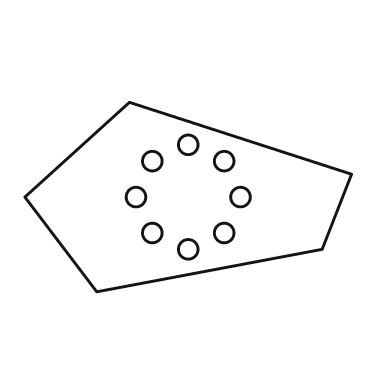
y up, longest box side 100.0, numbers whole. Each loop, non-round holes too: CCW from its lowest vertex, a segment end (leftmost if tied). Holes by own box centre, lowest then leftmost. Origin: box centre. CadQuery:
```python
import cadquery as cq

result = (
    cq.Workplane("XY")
    .moveTo(-28.0, -29.0)
    .lineTo(41.0, -16.0)
    .lineTo(50.0, 7.0)
    .lineTo(-18.0, 29.0)
    .lineTo(-50.0, 0.0)
    .close()
    .moveTo(0.0, -16.0)
    .circle(3.0)
    .moveTo(-11.0, -11.0)
    .circle(3.0)
    .moveTo(11.0, -11.0)
    .circle(3.0)
    .moveTo(-16.0, 0.0)
    .circle(3.0)
    .moveTo(16.0, 0.0)
    .circle(3.0)
    .moveTo(-11.0, 11.0)
    .circle(3.0)
    .moveTo(11.0, 11.0)
    .circle(3.0)
    .moveTo(0.0, 16.0)
    .circle(3.0)
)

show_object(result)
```